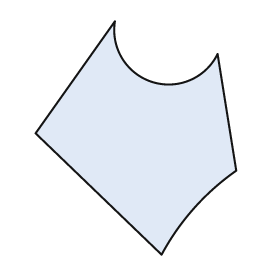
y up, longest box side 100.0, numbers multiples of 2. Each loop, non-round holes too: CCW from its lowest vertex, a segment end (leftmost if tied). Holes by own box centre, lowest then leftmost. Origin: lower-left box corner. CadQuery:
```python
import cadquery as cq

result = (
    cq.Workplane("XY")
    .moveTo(54.0, 0.0)
    .threePointArc((68.0, 20.0), (86.0, 36.0))
    .lineTo(78.0, 86.0)
    .threePointArc((50.0, 74.0), (34.0, 100.0))
    .lineTo(0.0, 52.0)
    .close()
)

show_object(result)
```